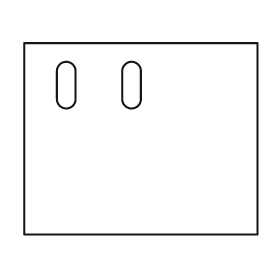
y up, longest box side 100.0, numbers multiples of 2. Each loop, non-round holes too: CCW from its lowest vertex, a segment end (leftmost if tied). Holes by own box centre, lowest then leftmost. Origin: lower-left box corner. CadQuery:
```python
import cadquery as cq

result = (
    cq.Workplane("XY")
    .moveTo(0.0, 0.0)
    .lineTo(100.0, 0.0)
    .lineTo(100.0, 82.0)
    .lineTo(0.0, 82.0)
    .close()
    .moveTo(14.0, 58.0)
    .threePointArc((18.0, 54.0), (22.0, 58.0))
    .lineTo(22.0, 70.0)
    .threePointArc((18.0, 74.0), (14.0, 70.0))
    .close()
    .moveTo(42.0, 58.0)
    .threePointArc((46.0, 54.0), (50.0, 58.0))
    .lineTo(50.0, 70.0)
    .threePointArc((46.0, 74.0), (42.0, 70.0))
    .close()
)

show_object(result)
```